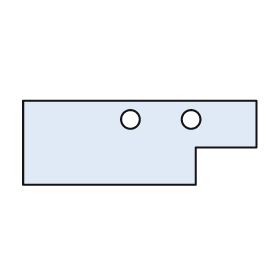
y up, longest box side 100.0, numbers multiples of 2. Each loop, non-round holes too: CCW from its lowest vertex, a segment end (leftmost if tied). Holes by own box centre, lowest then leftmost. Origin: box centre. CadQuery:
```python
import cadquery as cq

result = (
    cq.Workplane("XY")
    .moveTo(-50.0, -18.0)
    .lineTo(24.0, -18.0)
    .lineTo(24.0, -2.0)
    .lineTo(50.0, -2.0)
    .lineTo(50.0, 18.0)
    .lineTo(-50.0, 18.0)
    .close()
    .moveTo(-4.0, 10.0)
    .circle(4.0)
    .moveTo(22.0, 10.0)
    .circle(4.0)
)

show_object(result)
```